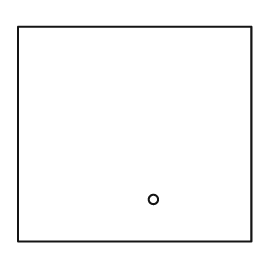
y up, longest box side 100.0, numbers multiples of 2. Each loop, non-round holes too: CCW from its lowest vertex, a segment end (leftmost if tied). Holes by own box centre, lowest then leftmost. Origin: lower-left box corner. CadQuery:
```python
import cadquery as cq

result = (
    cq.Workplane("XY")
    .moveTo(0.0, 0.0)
    .lineTo(100.0, 0.0)
    .lineTo(100.0, 92.0)
    .lineTo(0.0, 92.0)
    .close()
    .moveTo(58.0, 18.0)
    .circle(2.0)
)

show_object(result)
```